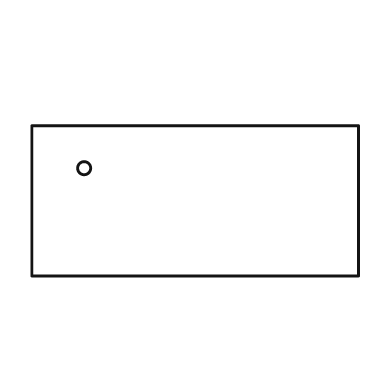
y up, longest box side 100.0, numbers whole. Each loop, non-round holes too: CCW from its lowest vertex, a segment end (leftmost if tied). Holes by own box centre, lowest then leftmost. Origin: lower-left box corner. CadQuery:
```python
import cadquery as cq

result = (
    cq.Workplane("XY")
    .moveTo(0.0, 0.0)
    .lineTo(100.0, 0.0)
    .lineTo(100.0, 46.0)
    .lineTo(0.0, 46.0)
    .close()
    .moveTo(16.0, 33.0)
    .circle(2.0)
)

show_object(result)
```